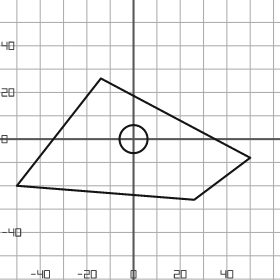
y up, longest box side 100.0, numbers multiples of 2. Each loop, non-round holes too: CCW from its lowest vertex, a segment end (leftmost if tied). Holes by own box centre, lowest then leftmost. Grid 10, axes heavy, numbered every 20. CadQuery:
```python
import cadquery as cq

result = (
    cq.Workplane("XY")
    .moveTo(26.0, -26.0)
    .lineTo(50.0, -8.0)
    .lineTo(-14.0, 26.0)
    .lineTo(-50.0, -20.0)
    .close()
    .moveTo(0.0, 0.0)
    .circle(6.0)
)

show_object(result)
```